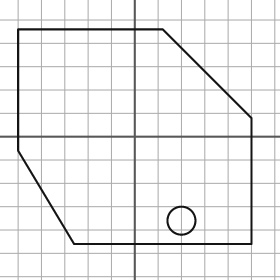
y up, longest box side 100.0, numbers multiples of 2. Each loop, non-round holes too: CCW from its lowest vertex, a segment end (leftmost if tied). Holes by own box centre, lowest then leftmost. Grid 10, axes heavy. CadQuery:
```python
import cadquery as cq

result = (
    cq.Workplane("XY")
    .moveTo(-26.0, -46.0)
    .lineTo(50.0, -46.0)
    .lineTo(50.0, 8.0)
    .lineTo(12.0, 46.0)
    .lineTo(-50.0, 46.0)
    .lineTo(-50.0, -6.0)
    .close()
    .moveTo(20.0, -36.0)
    .circle(6.0)
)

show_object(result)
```